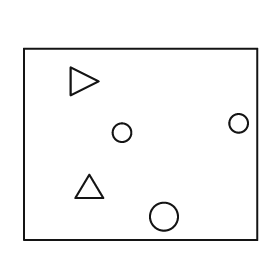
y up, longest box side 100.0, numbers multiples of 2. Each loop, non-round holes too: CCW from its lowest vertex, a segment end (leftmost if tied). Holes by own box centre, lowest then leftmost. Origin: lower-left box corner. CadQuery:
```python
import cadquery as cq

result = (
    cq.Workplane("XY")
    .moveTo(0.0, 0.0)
    .lineTo(100.0, 0.0)
    .lineTo(100.0, 82.0)
    .lineTo(0.0, 82.0)
    .close()
    .moveTo(60.0, 10.0)
    .circle(6.0)
    .moveTo(22.0, 18.0)
    .lineTo(34.0, 18.0)
    .lineTo(28.0, 28.0)
    .close()
    .moveTo(42.0, 46.0)
    .circle(4.0)
    .moveTo(92.0, 50.0)
    .circle(4.0)
    .moveTo(20.0, 62.0)
    .lineTo(32.0, 68.0)
    .lineTo(20.0, 74.0)
    .close()
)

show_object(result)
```